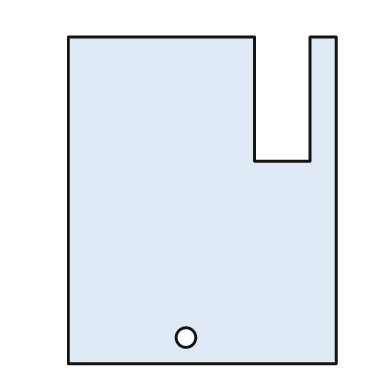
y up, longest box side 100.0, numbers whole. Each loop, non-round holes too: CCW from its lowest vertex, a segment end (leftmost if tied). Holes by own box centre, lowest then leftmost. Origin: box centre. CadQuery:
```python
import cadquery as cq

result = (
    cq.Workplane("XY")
    .moveTo(-41.0, -50.0)
    .lineTo(41.0, -50.0)
    .lineTo(41.0, 50.0)
    .lineTo(33.0, 50.0)
    .lineTo(33.0, 12.0)
    .lineTo(16.0, 12.0)
    .lineTo(16.0, 50.0)
    .lineTo(-41.0, 50.0)
    .close()
    .moveTo(-5.0, -42.0)
    .circle(3.0)
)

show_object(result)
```